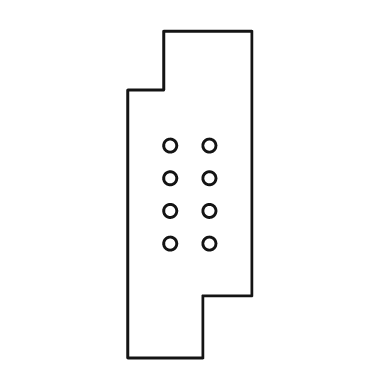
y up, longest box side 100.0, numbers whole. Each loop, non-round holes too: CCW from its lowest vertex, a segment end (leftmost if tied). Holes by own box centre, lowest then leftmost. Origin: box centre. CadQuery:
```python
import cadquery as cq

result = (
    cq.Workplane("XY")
    .moveTo(-19.0, -50.0)
    .lineTo(4.0, -50.0)
    .lineTo(4.0, -31.0)
    .lineTo(19.0, -31.0)
    .lineTo(19.0, 50.0)
    .lineTo(-8.0, 50.0)
    .lineTo(-8.0, 32.0)
    .lineTo(-19.0, 32.0)
    .close()
    .moveTo(-6.0, -15.0)
    .circle(2.0)
    .moveTo(6.0, -15.0)
    .circle(2.0)
    .moveTo(-6.0, -5.0)
    .circle(2.0)
    .moveTo(6.0, -5.0)
    .circle(2.0)
    .moveTo(-6.0, 5.0)
    .circle(2.0)
    .moveTo(6.0, 5.0)
    .circle(2.0)
    .moveTo(-6.0, 15.0)
    .circle(2.0)
    .moveTo(6.0, 15.0)
    .circle(2.0)
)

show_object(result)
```